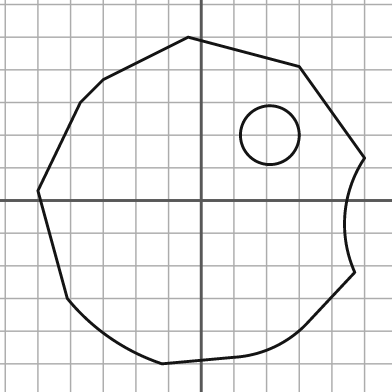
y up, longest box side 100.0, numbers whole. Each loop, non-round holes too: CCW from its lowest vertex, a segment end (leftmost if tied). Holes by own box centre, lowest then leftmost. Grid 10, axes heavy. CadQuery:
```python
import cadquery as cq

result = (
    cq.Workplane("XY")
    .moveTo(-12.0, -50.0)
    .lineTo(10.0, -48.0)
    .threePointArc((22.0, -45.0), (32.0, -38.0))
    .lineTo(47.0, -22.0)
    .threePointArc((44.0, -4.0), (50.0, 13.0))
    .lineTo(30.0, 41.0)
    .lineTo(-4.0, 50.0)
    .lineTo(-30.0, 37.0)
    .lineTo(-37.0, 30.0)
    .lineTo(-50.0, 3.0)
    .lineTo(-41.0, -30.0)
    .threePointArc((-28.0, -42.0), (-12.0, -50.0))
    .close()
    .moveTo(21.0, 20.0)
    .circle(9.0)
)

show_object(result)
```